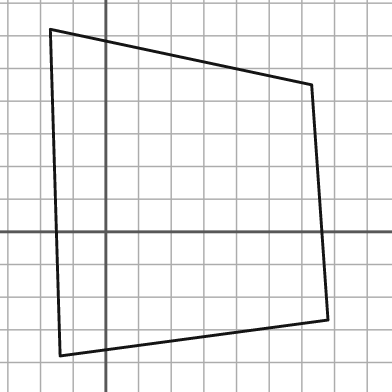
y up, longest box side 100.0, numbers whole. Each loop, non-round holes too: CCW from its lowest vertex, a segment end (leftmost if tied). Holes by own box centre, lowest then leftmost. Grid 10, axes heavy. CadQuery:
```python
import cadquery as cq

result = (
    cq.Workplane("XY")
    .moveTo(-14.0, -38.0)
    .lineTo(68.0, -27.0)
    .lineTo(63.0, 45.0)
    .lineTo(-17.0, 62.0)
    .close()
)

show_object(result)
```